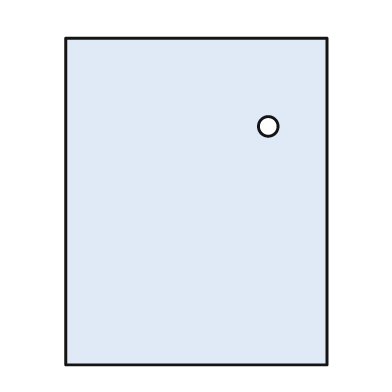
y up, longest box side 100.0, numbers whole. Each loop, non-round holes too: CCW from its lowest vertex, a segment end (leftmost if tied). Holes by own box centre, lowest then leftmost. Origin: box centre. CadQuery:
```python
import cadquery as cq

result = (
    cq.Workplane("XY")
    .moveTo(-40.0, -50.0)
    .lineTo(40.0, -50.0)
    .lineTo(40.0, 50.0)
    .lineTo(-40.0, 50.0)
    .close()
    .moveTo(22.0, 23.0)
    .circle(3.0)
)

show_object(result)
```